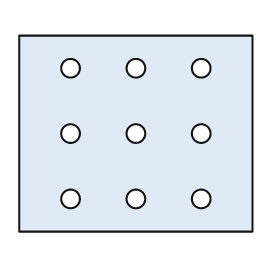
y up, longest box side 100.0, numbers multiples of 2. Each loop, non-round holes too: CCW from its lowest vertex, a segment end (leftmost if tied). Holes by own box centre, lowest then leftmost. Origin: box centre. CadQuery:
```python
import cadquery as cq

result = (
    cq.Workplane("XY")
    .moveTo(-50.0, -42.0)
    .lineTo(50.0, -42.0)
    .lineTo(50.0, 42.0)
    .lineTo(-50.0, 42.0)
    .close()
    .moveTo(-28.0, -28.0)
    .circle(4.0)
    .moveTo(0.0, -28.0)
    .circle(4.0)
    .moveTo(28.0, -28.0)
    .circle(4.0)
    .moveTo(-28.0, 0.0)
    .circle(4.0)
    .moveTo(0.0, 0.0)
    .circle(4.0)
    .moveTo(28.0, 0.0)
    .circle(4.0)
    .moveTo(-28.0, 28.0)
    .circle(4.0)
    .moveTo(0.0, 28.0)
    .circle(4.0)
    .moveTo(28.0, 28.0)
    .circle(4.0)
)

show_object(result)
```